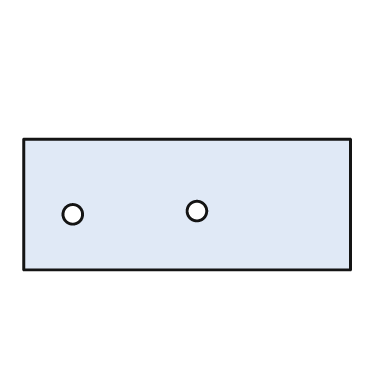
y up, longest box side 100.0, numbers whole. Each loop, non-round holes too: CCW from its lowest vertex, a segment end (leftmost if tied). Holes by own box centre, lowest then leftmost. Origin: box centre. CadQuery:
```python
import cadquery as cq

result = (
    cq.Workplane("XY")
    .moveTo(-50.0, -20.0)
    .lineTo(50.0, -20.0)
    .lineTo(50.0, 20.0)
    .lineTo(-50.0, 20.0)
    .close()
    .moveTo(-35.0, -3.0)
    .circle(3.0)
    .moveTo(3.0, -2.0)
    .circle(3.0)
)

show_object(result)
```